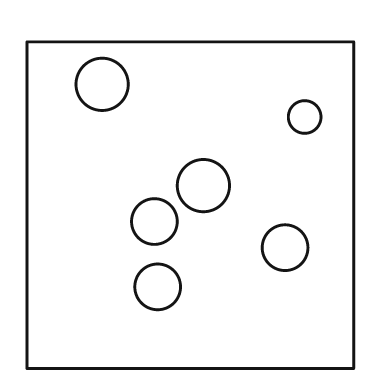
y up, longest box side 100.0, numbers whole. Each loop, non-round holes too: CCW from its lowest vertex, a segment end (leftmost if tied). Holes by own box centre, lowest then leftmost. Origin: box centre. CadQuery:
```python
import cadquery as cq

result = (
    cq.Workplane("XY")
    .moveTo(-50.0, -50.0)
    .lineTo(50.0, -50.0)
    .lineTo(50.0, 50.0)
    .lineTo(-50.0, 50.0)
    .close()
    .moveTo(-10.0, -25.0)
    .circle(7.0)
    .moveTo(29.0, -13.0)
    .circle(7.0)
    .moveTo(-11.0, -5.0)
    .circle(7.0)
    .moveTo(4.0, 6.0)
    .circle(8.0)
    .moveTo(35.0, 27.0)
    .circle(5.0)
    .moveTo(-27.0, 37.0)
    .circle(8.0)
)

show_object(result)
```